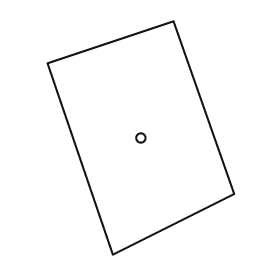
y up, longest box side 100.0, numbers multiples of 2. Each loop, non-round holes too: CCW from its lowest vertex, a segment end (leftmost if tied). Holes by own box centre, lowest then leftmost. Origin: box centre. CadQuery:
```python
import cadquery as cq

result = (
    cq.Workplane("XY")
    .moveTo(-12.0, -50.0)
    .lineTo(40.0, -24.0)
    .lineTo(14.0, 50.0)
    .lineTo(-40.0, 32.0)
    .close()
    .moveTo(0.0, 0.0)
    .circle(2.0)
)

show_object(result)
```